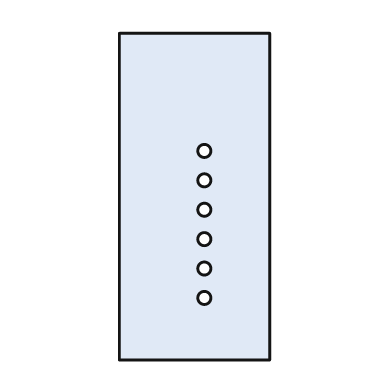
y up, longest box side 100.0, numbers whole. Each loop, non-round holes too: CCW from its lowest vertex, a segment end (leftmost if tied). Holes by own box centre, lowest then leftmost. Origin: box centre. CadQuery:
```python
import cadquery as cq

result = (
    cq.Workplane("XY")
    .moveTo(-23.0, -50.0)
    .lineTo(23.0, -50.0)
    .lineTo(23.0, 50.0)
    .lineTo(-23.0, 50.0)
    .close()
    .moveTo(3.0, -31.0)
    .circle(2.0)
    .moveTo(3.0, -22.0)
    .circle(2.0)
    .moveTo(3.0, -13.0)
    .circle(2.0)
    .moveTo(3.0, -4.0)
    .circle(2.0)
    .moveTo(3.0, 5.0)
    .circle(2.0)
    .moveTo(3.0, 14.0)
    .circle(2.0)
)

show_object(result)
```